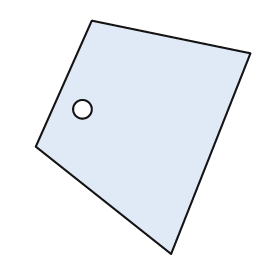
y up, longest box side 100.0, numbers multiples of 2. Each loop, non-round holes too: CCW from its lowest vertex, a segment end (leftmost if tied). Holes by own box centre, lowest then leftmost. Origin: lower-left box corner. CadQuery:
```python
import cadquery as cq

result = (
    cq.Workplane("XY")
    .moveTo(58.0, 0.0)
    .lineTo(92.0, 86.0)
    .lineTo(24.0, 100.0)
    .lineTo(0.0, 46.0)
    .close()
    .moveTo(20.0, 62.0)
    .circle(4.0)
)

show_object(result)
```